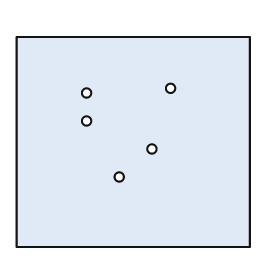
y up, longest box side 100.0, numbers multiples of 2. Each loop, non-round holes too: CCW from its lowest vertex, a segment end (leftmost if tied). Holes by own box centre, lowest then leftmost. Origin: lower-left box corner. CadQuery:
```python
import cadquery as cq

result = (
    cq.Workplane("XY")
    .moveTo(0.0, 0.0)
    .lineTo(100.0, 0.0)
    .lineTo(100.0, 90.0)
    .lineTo(0.0, 90.0)
    .close()
    .moveTo(44.0, 30.0)
    .circle(2.0)
    .moveTo(58.0, 42.0)
    .circle(2.0)
    .moveTo(30.0, 54.0)
    .circle(2.0)
    .moveTo(30.0, 66.0)
    .circle(2.0)
    .moveTo(66.0, 68.0)
    .circle(2.0)
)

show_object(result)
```